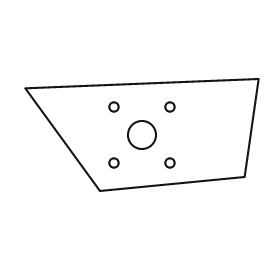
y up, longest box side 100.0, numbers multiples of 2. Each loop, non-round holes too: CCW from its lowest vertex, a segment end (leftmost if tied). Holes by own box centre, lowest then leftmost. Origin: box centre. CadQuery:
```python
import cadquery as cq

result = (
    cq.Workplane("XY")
    .moveTo(-18.0, -24.0)
    .lineTo(44.0, -18.0)
    .lineTo(50.0, 24.0)
    .lineTo(-50.0, 20.0)
    .close()
    .moveTo(-12.0, -12.0)
    .circle(2.0)
    .moveTo(12.0, -12.0)
    .circle(2.0)
    .moveTo(0.0, 0.0)
    .circle(6.0)
    .moveTo(-12.0, 12.0)
    .circle(2.0)
    .moveTo(12.0, 12.0)
    .circle(2.0)
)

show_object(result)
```